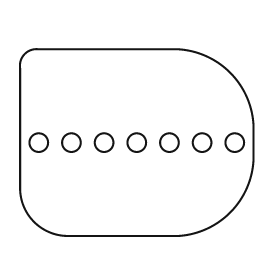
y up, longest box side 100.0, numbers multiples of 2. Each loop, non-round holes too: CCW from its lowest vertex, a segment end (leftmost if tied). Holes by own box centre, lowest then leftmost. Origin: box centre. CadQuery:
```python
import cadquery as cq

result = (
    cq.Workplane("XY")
    .moveTo(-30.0, -40.0)
    .lineTo(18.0, -40.0)
    .threePointArc((40.0, -30.0), (50.0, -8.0))
    .lineTo(50.0, 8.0)
    .threePointArc((40.0, 30.0), (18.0, 40.0))
    .lineTo(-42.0, 40.0)
    .threePointArc((-48.0, 38.0), (-50.0, 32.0))
    .lineTo(-50.0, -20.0)
    .threePointArc((-44.0, -34.0), (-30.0, -40.0))
    .close()
    .moveTo(-42.0, 0.0)
    .circle(4.0)
    .moveTo(-28.0, 0.0)
    .circle(4.0)
    .moveTo(-14.0, 0.0)
    .circle(4.0)
    .moveTo(0.0, 0.0)
    .circle(4.0)
    .moveTo(14.0, 0.0)
    .circle(4.0)
    .moveTo(28.0, 0.0)
    .circle(4.0)
    .moveTo(42.0, 0.0)
    .circle(4.0)
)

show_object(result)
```